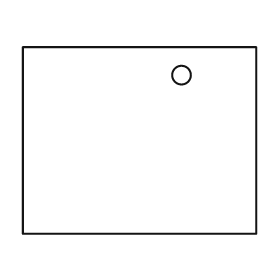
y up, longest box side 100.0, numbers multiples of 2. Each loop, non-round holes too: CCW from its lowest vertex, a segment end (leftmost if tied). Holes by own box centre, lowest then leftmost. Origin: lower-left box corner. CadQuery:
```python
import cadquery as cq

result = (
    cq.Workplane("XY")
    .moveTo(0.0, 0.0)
    .lineTo(100.0, 0.0)
    .lineTo(100.0, 80.0)
    .lineTo(0.0, 80.0)
    .close()
    .moveTo(68.0, 68.0)
    .circle(4.0)
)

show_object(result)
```